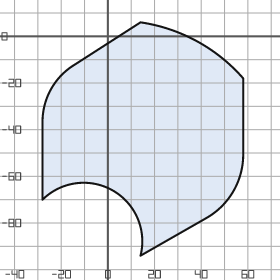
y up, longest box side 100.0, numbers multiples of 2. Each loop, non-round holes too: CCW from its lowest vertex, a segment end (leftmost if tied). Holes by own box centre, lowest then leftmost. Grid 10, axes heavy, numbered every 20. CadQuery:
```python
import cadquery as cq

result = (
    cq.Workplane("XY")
    .moveTo(14.0, -94.0)
    .lineTo(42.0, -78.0)
    .threePointArc((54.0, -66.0), (58.0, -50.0))
    .lineTo(58.0, -18.0)
    .threePointArc((38.0, -2.0), (14.0, 6.0))
    .lineTo(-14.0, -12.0)
    .threePointArc((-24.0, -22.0), (-28.0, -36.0))
    .lineTo(-28.0, -70.0)
    .threePointArc((2.0, -66.0), (14.0, -94.0))
    .close()
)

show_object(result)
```